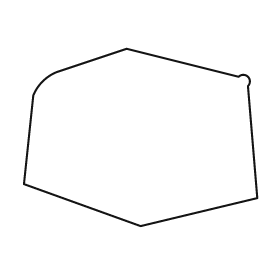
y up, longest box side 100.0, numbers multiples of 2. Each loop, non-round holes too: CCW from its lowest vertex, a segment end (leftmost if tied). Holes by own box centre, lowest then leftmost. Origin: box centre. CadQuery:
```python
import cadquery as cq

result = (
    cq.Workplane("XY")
    .moveTo(0.0, -38.0)
    .lineTo(50.0, -26.0)
    .lineTo(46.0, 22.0)
    .threePointArc((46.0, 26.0), (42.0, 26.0))
    .lineTo(-6.0, 38.0)
    .lineTo(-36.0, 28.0)
    .threePointArc((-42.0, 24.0), (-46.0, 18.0))
    .lineTo(-50.0, -20.0)
    .close()
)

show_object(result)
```